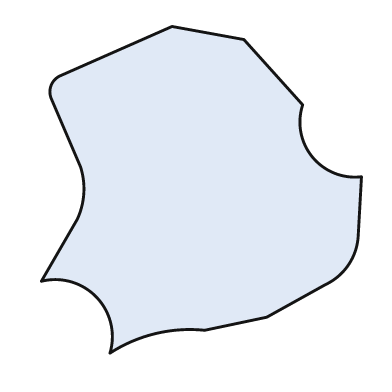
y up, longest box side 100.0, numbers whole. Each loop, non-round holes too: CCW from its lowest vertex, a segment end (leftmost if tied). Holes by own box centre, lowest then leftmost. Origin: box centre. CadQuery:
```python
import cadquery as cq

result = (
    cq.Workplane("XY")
    .moveTo(-28.0, -50.0)
    .threePointArc((-14.0, -44.0), (1.0, -43.0))
    .lineTo(20.0, -39.0)
    .lineTo(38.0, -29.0)
    .threePointArc((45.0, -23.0), (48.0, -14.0))
    .lineTo(49.0, 4.0)
    .threePointArc((34.0, 10.0), (31.0, 26.0))
    .lineTo(13.0, 46.0)
    .lineTo(-9.0, 50.0)
    .lineTo(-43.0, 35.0)
    .threePointArc((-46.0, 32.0), (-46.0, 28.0))
    .lineTo(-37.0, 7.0)
    .threePointArc((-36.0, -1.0), (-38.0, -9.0))
    .lineTo(-49.0, -28.0)
    .threePointArc((-32.0, -33.0), (-28.0, -50.0))
    .close()
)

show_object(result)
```